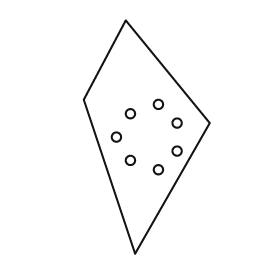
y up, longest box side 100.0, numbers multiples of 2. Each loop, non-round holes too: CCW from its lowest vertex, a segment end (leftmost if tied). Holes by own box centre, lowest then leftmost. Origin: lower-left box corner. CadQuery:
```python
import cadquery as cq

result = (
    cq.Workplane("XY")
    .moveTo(22.0, 0.0)
    .lineTo(54.0, 56.0)
    .lineTo(18.0, 100.0)
    .lineTo(0.0, 66.0)
    .close()
    .moveTo(32.0, 36.0)
    .circle(2.0)
    .moveTo(20.0, 40.0)
    .circle(2.0)
    .moveTo(40.0, 44.0)
    .circle(2.0)
    .moveTo(14.0, 50.0)
    .circle(2.0)
    .moveTo(40.0, 56.0)
    .circle(2.0)
    .moveTo(20.0, 60.0)
    .circle(2.0)
    .moveTo(32.0, 64.0)
    .circle(2.0)
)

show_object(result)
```